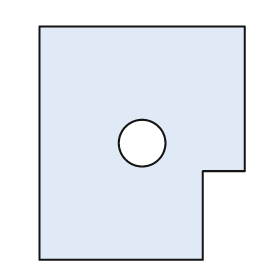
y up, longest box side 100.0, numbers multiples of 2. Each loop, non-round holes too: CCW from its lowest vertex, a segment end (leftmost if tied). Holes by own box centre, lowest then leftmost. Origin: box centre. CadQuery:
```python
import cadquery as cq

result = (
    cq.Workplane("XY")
    .moveTo(-44.0, -50.0)
    .lineTo(26.0, -50.0)
    .lineTo(26.0, -12.0)
    .lineTo(44.0, -12.0)
    .lineTo(44.0, 50.0)
    .lineTo(-44.0, 50.0)
    .close()
    .moveTo(0.0, 0.0)
    .circle(10.0)
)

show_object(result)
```